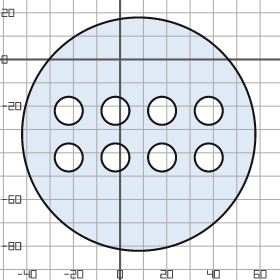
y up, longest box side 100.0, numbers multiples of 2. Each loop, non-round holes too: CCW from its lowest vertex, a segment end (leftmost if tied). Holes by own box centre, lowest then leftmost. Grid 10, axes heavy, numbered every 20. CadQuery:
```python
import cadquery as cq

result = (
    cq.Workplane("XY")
    .moveTo(8.0, -32.0)
    .circle(50.0)
    .moveTo(-22.0, -42.0)
    .circle(6.0)
    .moveTo(-2.0, -42.0)
    .circle(6.0)
    .moveTo(18.0, -42.0)
    .circle(6.0)
    .moveTo(38.0, -42.0)
    .circle(6.0)
    .moveTo(-22.0, -22.0)
    .circle(6.0)
    .moveTo(-2.0, -22.0)
    .circle(6.0)
    .moveTo(18.0, -22.0)
    .circle(6.0)
    .moveTo(38.0, -22.0)
    .circle(6.0)
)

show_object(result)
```